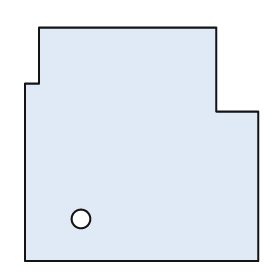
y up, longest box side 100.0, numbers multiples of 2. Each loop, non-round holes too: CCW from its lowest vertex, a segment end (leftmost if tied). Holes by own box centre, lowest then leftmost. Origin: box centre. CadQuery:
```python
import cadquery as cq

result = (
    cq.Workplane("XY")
    .moveTo(-50.0, -50.0)
    .lineTo(50.0, -50.0)
    .lineTo(50.0, 14.0)
    .lineTo(32.0, 14.0)
    .lineTo(32.0, 50.0)
    .lineTo(-44.0, 50.0)
    .lineTo(-44.0, 26.0)
    .lineTo(-50.0, 26.0)
    .close()
    .moveTo(-26.0, -32.0)
    .circle(4.0)
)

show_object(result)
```